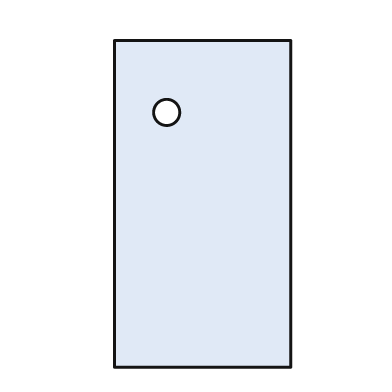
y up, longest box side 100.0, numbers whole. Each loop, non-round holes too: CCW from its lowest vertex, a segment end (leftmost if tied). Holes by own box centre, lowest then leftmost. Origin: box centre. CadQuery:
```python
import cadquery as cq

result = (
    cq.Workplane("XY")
    .moveTo(-27.0, -50.0)
    .lineTo(27.0, -50.0)
    .lineTo(27.0, 50.0)
    .lineTo(-27.0, 50.0)
    .close()
    .moveTo(-11.0, 28.0)
    .circle(4.0)
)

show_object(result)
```